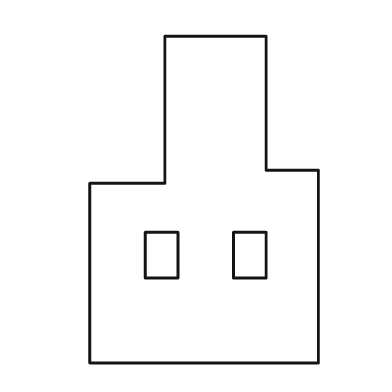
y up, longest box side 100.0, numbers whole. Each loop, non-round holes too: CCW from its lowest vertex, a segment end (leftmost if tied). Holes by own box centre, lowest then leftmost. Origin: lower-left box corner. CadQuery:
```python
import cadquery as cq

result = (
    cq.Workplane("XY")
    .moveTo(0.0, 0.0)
    .lineTo(70.0, 0.0)
    .lineTo(70.0, 59.0)
    .lineTo(54.0, 59.0)
    .lineTo(54.0, 100.0)
    .lineTo(23.0, 100.0)
    .lineTo(23.0, 55.0)
    .lineTo(0.0, 55.0)
    .close()
    .moveTo(17.0, 26.0)
    .lineTo(27.0, 26.0)
    .lineTo(27.0, 40.0)
    .lineTo(17.0, 40.0)
    .close()
    .moveTo(44.0, 26.0)
    .lineTo(54.0, 26.0)
    .lineTo(54.0, 40.0)
    .lineTo(44.0, 40.0)
    .close()
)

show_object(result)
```